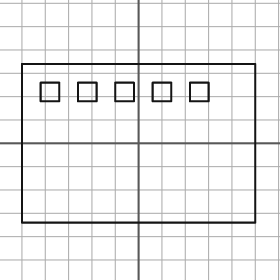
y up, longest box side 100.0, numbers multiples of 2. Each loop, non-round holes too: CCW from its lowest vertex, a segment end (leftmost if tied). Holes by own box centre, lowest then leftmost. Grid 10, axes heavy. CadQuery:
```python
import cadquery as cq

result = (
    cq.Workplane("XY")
    .moveTo(-50.0, -34.0)
    .lineTo(50.0, -34.0)
    .lineTo(50.0, 34.0)
    .lineTo(-50.0, 34.0)
    .close()
    .moveTo(-42.0, 18.0)
    .lineTo(-34.0, 18.0)
    .lineTo(-34.0, 26.0)
    .lineTo(-42.0, 26.0)
    .close()
    .moveTo(-26.0, 18.0)
    .lineTo(-18.0, 18.0)
    .lineTo(-18.0, 26.0)
    .lineTo(-26.0, 26.0)
    .close()
    .moveTo(-10.0, 18.0)
    .lineTo(-2.0, 18.0)
    .lineTo(-2.0, 26.0)
    .lineTo(-10.0, 26.0)
    .close()
    .moveTo(6.0, 18.0)
    .lineTo(14.0, 18.0)
    .lineTo(14.0, 26.0)
    .lineTo(6.0, 26.0)
    .close()
    .moveTo(22.0, 18.0)
    .lineTo(30.0, 18.0)
    .lineTo(30.0, 26.0)
    .lineTo(22.0, 26.0)
    .close()
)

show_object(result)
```